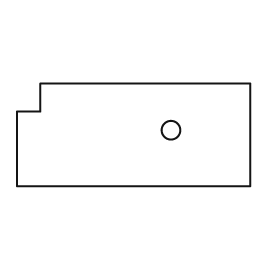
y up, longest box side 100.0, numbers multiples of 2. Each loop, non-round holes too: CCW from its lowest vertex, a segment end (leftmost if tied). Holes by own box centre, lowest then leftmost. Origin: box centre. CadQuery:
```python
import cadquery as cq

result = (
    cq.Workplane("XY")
    .moveTo(-50.0, -22.0)
    .lineTo(50.0, -22.0)
    .lineTo(50.0, 22.0)
    .lineTo(-40.0, 22.0)
    .lineTo(-40.0, 10.0)
    .lineTo(-50.0, 10.0)
    .close()
    .moveTo(16.0, 2.0)
    .circle(4.0)
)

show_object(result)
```